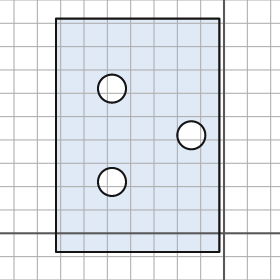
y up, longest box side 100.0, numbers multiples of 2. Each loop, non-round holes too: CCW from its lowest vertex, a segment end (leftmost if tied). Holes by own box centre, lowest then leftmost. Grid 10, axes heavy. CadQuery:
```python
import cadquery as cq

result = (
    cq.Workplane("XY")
    .moveTo(-72.0, -8.0)
    .lineTo(-2.0, -8.0)
    .lineTo(-2.0, 92.0)
    .lineTo(-72.0, 92.0)
    .close()
    .moveTo(-48.0, 22.0)
    .circle(6.0)
    .moveTo(-14.0, 42.0)
    .circle(6.0)
    .moveTo(-48.0, 62.0)
    .circle(6.0)
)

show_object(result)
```